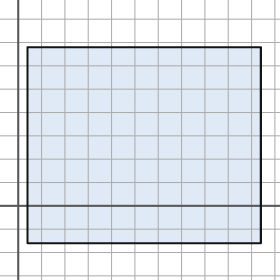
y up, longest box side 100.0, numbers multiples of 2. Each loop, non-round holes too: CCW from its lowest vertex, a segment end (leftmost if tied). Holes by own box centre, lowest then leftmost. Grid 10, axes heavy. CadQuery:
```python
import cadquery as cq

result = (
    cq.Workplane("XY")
    .moveTo(4.0, -16.0)
    .lineTo(104.0, -16.0)
    .lineTo(104.0, 68.0)
    .lineTo(4.0, 68.0)
    .close()
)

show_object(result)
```